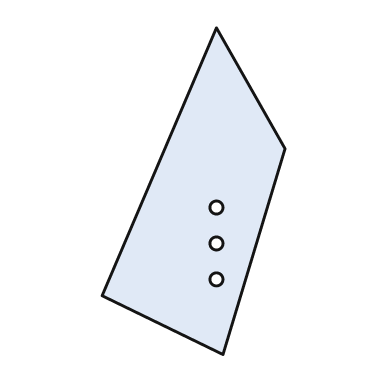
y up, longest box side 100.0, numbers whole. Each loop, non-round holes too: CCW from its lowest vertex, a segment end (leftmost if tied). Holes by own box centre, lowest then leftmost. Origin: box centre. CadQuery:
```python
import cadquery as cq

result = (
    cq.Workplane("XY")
    .moveTo(9.0, -50.0)
    .lineTo(28.0, 13.0)
    .lineTo(7.0, 50.0)
    .lineTo(-28.0, -32.0)
    .close()
    .moveTo(7.0, -27.0)
    .circle(2.0)
    .moveTo(7.0, -16.0)
    .circle(2.0)
    .moveTo(7.0, -5.0)
    .circle(2.0)
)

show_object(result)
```